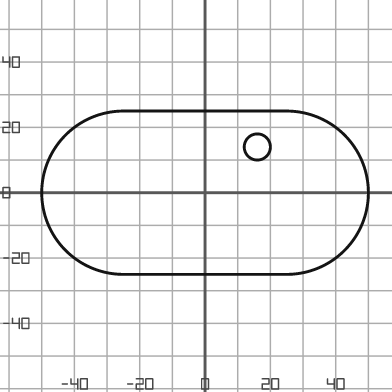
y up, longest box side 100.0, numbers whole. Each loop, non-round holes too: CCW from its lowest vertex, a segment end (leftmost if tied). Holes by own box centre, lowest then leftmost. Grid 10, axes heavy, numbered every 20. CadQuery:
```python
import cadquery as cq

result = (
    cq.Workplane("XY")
    .moveTo(-25.0, -25.0)
    .lineTo(25.0, -25.0)
    .threePointArc((50.0, 0.0), (25.0, 25.0))
    .lineTo(-25.0, 25.0)
    .threePointArc((-50.0, 0.0), (-25.0, -25.0))
    .close()
    .moveTo(16.0, 14.0)
    .circle(4.0)
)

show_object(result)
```